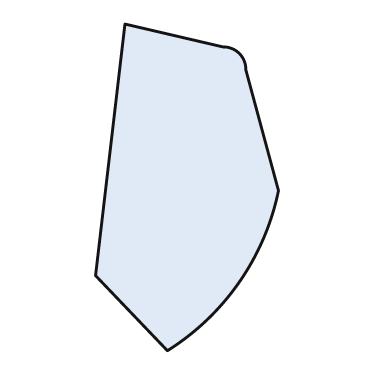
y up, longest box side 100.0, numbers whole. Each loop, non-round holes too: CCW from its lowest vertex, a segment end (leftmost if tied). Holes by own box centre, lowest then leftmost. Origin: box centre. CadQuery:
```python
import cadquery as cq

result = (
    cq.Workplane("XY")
    .moveTo(-6.0, -50.0)
    .threePointArc((16.0, -29.0), (28.0, -1.0))
    .lineTo(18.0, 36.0)
    .threePointArc((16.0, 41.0), (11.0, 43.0))
    .lineTo(-19.0, 50.0)
    .lineTo(-28.0, -27.0)
    .close()
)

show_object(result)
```